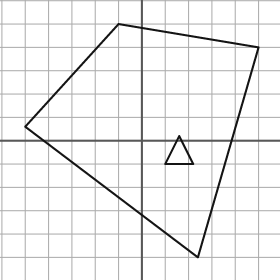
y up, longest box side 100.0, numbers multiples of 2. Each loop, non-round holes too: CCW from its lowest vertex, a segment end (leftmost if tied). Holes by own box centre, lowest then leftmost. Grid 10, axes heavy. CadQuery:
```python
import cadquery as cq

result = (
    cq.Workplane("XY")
    .moveTo(24.0, -50.0)
    .lineTo(50.0, 40.0)
    .lineTo(-10.0, 50.0)
    .lineTo(-50.0, 6.0)
    .close()
    .moveTo(10.0, -10.0)
    .lineTo(22.0, -10.0)
    .lineTo(16.0, 2.0)
    .close()
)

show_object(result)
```